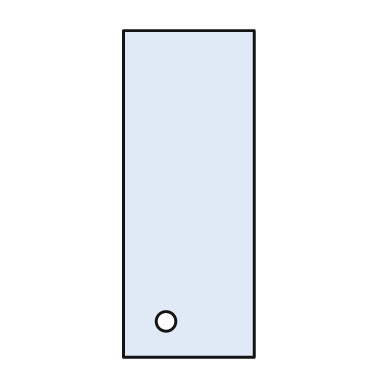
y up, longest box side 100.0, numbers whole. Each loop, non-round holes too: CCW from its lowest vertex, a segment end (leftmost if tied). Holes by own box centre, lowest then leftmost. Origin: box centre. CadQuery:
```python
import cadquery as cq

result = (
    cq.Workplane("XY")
    .moveTo(-20.0, -50.0)
    .lineTo(20.0, -50.0)
    .lineTo(20.0, 50.0)
    .lineTo(-20.0, 50.0)
    .close()
    .moveTo(-7.0, -39.0)
    .circle(3.0)
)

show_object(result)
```